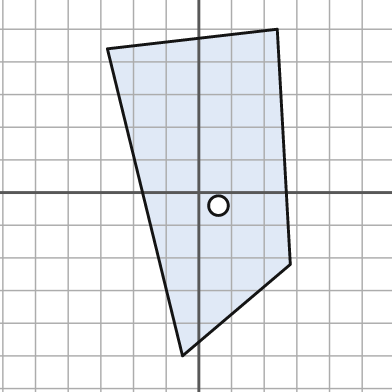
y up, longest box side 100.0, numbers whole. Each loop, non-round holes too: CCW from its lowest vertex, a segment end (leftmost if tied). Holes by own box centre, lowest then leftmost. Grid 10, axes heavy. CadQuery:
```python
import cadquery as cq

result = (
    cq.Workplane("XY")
    .moveTo(-5.0, -50.0)
    .lineTo(28.0, -22.0)
    .lineTo(24.0, 50.0)
    .lineTo(-28.0, 44.0)
    .close()
    .moveTo(6.0, -4.0)
    .circle(3.0)
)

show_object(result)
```